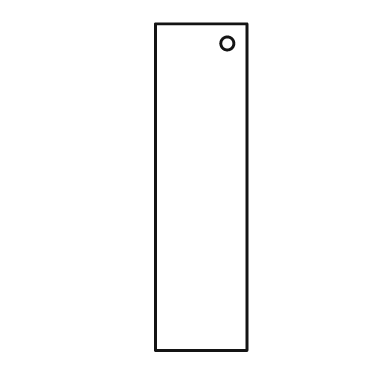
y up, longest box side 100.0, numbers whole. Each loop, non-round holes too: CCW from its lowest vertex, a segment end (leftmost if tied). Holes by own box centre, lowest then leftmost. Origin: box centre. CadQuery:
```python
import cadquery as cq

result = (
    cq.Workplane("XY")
    .moveTo(-14.0, -50.0)
    .lineTo(14.0, -50.0)
    .lineTo(14.0, 50.0)
    .lineTo(-14.0, 50.0)
    .close()
    .moveTo(8.0, 44.0)
    .circle(2.0)
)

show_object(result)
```